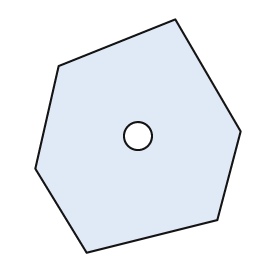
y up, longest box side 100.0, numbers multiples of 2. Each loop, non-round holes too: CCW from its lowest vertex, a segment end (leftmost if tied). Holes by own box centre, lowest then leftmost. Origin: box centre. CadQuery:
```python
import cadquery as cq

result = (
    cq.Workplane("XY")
    .moveTo(-22.0, -50.0)
    .lineTo(34.0, -36.0)
    .lineTo(44.0, 2.0)
    .lineTo(16.0, 50.0)
    .lineTo(-34.0, 30.0)
    .lineTo(-44.0, -14.0)
    .close()
    .moveTo(0.0, 0.0)
    .circle(6.0)
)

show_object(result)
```